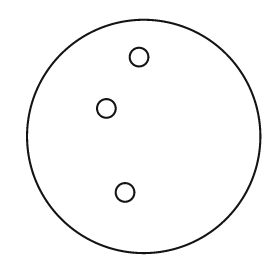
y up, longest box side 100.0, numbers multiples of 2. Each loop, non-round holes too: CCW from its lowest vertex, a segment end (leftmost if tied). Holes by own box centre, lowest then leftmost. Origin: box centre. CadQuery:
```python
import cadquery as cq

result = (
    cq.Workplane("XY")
    .moveTo(0.0, 0.0)
    .circle(50.0)
    .moveTo(-8.0, -24.0)
    .circle(4.0)
    .moveTo(-16.0, 12.0)
    .circle(4.0)
    .moveTo(-2.0, 34.0)
    .circle(4.0)
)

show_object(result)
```